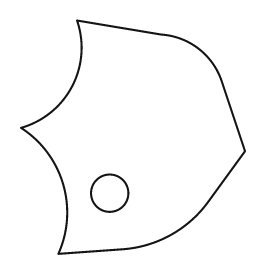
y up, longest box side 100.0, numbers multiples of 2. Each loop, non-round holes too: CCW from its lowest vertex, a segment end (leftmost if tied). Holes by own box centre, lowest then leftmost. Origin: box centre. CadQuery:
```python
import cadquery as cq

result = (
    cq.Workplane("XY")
    .moveTo(-32.0, -50.0)
    .lineTo(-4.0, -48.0)
    .threePointArc((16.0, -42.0), (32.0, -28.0))
    .lineTo(48.0, -6.0)
    .lineTo(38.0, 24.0)
    .threePointArc((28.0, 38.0), (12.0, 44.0))
    .lineTo(-24.0, 50.0)
    .threePointArc((-26.0, 22.0), (-48.0, 4.0))
    .threePointArc((-30.0, -20.0), (-32.0, -50.0))
    .close()
    .moveTo(-10.0, -24.0)
    .circle(8.0)
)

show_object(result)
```